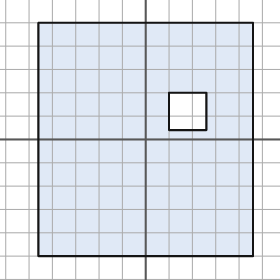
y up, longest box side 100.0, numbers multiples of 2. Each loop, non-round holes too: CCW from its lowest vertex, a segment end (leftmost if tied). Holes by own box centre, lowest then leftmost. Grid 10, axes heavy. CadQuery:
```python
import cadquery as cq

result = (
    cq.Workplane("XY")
    .moveTo(-46.0, -50.0)
    .lineTo(46.0, -50.0)
    .lineTo(46.0, 50.0)
    .lineTo(-46.0, 50.0)
    .close()
    .moveTo(10.0, 4.0)
    .lineTo(26.0, 4.0)
    .lineTo(26.0, 20.0)
    .lineTo(10.0, 20.0)
    .close()
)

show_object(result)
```